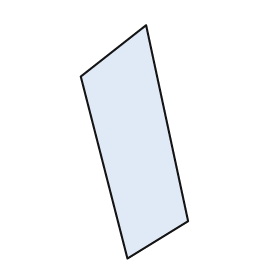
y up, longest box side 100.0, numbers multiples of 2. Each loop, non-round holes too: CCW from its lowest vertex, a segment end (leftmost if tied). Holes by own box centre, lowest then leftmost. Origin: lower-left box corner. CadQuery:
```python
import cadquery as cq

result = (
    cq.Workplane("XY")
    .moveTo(20.0, 0.0)
    .lineTo(46.0, 16.0)
    .lineTo(28.0, 100.0)
    .lineTo(0.0, 78.0)
    .close()
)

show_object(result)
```